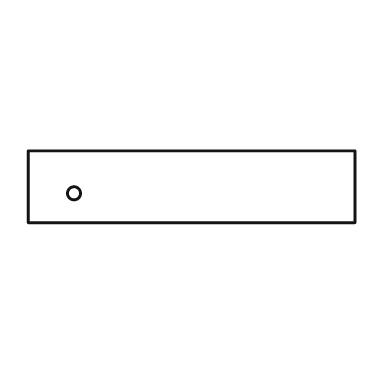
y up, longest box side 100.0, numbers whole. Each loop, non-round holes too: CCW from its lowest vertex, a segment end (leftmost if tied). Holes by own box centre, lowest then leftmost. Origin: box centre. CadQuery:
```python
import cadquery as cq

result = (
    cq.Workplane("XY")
    .moveTo(-50.0, -11.0)
    .lineTo(50.0, -11.0)
    .lineTo(50.0, 11.0)
    .lineTo(-50.0, 11.0)
    .close()
    .moveTo(-36.0, -2.0)
    .circle(2.0)
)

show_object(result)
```